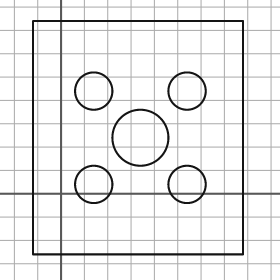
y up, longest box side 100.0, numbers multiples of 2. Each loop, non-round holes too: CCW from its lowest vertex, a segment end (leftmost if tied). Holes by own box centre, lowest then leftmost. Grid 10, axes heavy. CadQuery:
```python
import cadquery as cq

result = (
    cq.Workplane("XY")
    .moveTo(-12.0, -26.0)
    .lineTo(78.0, -26.0)
    .lineTo(78.0, 74.0)
    .lineTo(-12.0, 74.0)
    .close()
    .moveTo(14.0, 4.0)
    .circle(8.0)
    .moveTo(54.0, 4.0)
    .circle(8.0)
    .moveTo(34.0, 24.0)
    .circle(12.0)
    .moveTo(14.0, 44.0)
    .circle(8.0)
    .moveTo(54.0, 44.0)
    .circle(8.0)
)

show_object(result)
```